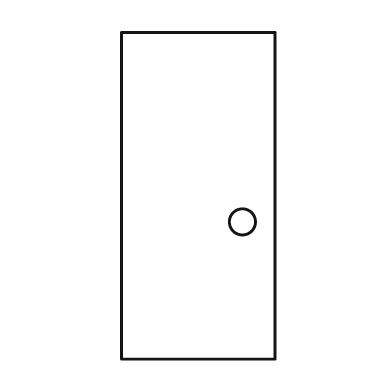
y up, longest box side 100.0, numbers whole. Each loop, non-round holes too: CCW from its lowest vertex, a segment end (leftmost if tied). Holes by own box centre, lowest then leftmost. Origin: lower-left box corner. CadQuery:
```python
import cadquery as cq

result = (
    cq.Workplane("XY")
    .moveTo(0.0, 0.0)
    .lineTo(47.0, 0.0)
    .lineTo(47.0, 100.0)
    .lineTo(0.0, 100.0)
    .close()
    .moveTo(37.0, 42.0)
    .circle(4.0)
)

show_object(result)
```